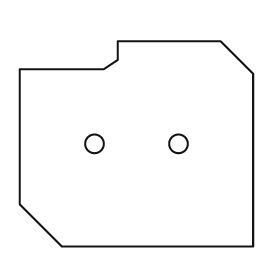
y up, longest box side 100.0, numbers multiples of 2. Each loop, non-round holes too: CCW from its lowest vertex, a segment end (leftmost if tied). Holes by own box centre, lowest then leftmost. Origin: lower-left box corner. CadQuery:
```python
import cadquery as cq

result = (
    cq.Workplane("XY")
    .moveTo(18.0, 0.0)
    .lineTo(100.0, 0.0)
    .lineTo(100.0, 74.0)
    .lineTo(86.0, 88.0)
    .lineTo(42.0, 88.0)
    .lineTo(42.0, 80.0)
    .lineTo(36.0, 76.0)
    .lineTo(0.0, 76.0)
    .lineTo(0.0, 18.0)
    .close()
    .moveTo(32.0, 44.0)
    .circle(4.0)
    .moveTo(68.0, 44.0)
    .circle(4.0)
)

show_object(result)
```